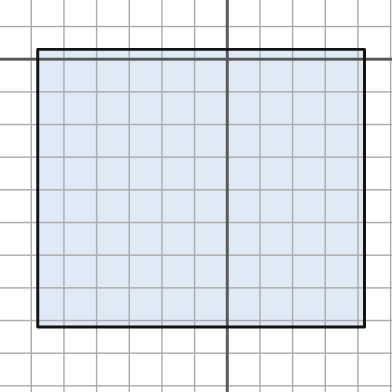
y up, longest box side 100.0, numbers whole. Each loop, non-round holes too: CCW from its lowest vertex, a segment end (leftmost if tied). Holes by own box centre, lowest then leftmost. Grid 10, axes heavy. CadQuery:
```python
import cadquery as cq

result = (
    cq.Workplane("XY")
    .moveTo(-58.0, -82.0)
    .lineTo(42.0, -82.0)
    .lineTo(42.0, 3.0)
    .lineTo(-58.0, 3.0)
    .close()
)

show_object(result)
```